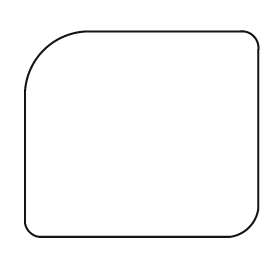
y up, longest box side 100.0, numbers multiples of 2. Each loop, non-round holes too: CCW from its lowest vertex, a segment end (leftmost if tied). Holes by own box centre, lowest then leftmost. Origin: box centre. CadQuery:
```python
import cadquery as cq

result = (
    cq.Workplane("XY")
    .moveTo(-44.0, -44.0)
    .lineTo(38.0, -44.0)
    .threePointArc((46.0, -40.0), (50.0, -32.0))
    .lineTo(50.0, 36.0)
    .threePointArc((48.0, 42.0), (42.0, 44.0))
    .lineTo(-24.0, 44.0)
    .threePointArc((-42.0, 36.0), (-50.0, 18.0))
    .lineTo(-50.0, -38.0)
    .threePointArc((-48.0, -42.0), (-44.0, -44.0))
    .close()
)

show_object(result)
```